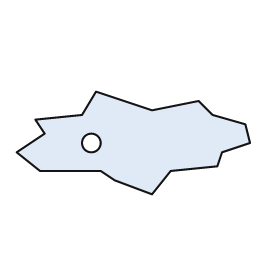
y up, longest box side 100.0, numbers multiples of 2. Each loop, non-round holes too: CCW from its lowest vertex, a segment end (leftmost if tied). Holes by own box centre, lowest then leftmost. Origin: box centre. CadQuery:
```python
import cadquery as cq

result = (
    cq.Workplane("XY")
    .moveTo(8.0, -22.0)
    .lineTo(16.0, -12.0)
    .lineTo(36.0, -10.0)
    .lineTo(38.0, -4.0)
    .lineTo(50.0, 0.0)
    .lineTo(48.0, 8.0)
    .lineTo(34.0, 12.0)
    .lineTo(28.0, 18.0)
    .lineTo(8.0, 14.0)
    .lineTo(-16.0, 22.0)
    .lineTo(-22.0, 12.0)
    .lineTo(-42.0, 10.0)
    .lineTo(-38.0, 4.0)
    .lineTo(-50.0, -4.0)
    .lineTo(-40.0, -12.0)
    .lineTo(-14.0, -12.0)
    .lineTo(-8.0, -16.0)
    .close()
    .moveTo(-18.0, 0.0)
    .circle(4.0)
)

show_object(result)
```